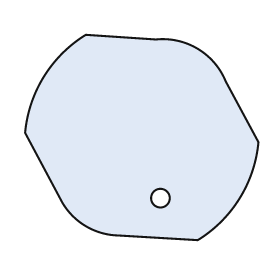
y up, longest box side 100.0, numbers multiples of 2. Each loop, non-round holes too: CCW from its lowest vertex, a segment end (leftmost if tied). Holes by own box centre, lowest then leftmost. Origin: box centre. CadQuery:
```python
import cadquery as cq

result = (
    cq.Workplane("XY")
    .moveTo(24.0, -44.0)
    .threePointArc((42.0, -26.0), (50.0, -2.0))
    .lineTo(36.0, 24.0)
    .threePointArc((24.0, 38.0), (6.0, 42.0))
    .lineTo(-24.0, 44.0)
    .threePointArc((-42.0, 26.0), (-50.0, 2.0))
    .lineTo(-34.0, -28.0)
    .threePointArc((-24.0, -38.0), (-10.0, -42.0))
    .close()
    .moveTo(8.0, -26.0)
    .circle(4.0)
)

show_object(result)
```